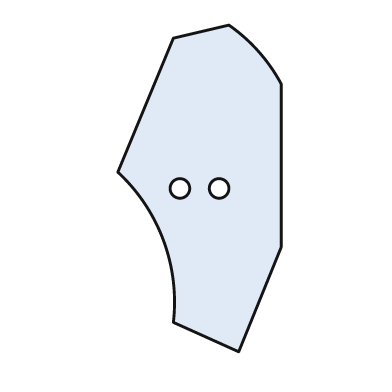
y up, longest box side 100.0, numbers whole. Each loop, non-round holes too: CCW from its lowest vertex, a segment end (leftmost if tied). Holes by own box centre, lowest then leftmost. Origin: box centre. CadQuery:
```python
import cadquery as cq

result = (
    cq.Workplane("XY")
    .moveTo(12.0, -50.0)
    .lineTo(25.0, -18.0)
    .lineTo(25.0, 32.0)
    .threePointArc((18.0, 42.0), (9.0, 50.0))
    .lineTo(-8.0, 46.0)
    .lineTo(-25.0, 5.0)
    .threePointArc((-11.0, -16.0), (-8.0, -41.0))
    .close()
    .moveTo(-6.0, 0.0)
    .circle(3.0)
    .moveTo(6.0, 0.0)
    .circle(3.0)
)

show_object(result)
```